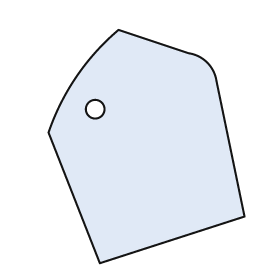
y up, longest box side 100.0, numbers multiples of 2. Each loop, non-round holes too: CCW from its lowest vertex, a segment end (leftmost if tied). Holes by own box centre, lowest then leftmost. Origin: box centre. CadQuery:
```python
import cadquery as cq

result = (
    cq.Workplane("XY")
    .moveTo(-20.0, -50.0)
    .lineTo(42.0, -30.0)
    .lineTo(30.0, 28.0)
    .threePointArc((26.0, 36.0), (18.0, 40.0))
    .lineTo(-12.0, 50.0)
    .threePointArc((-30.0, 30.0), (-42.0, 6.0))
    .close()
    .moveTo(-22.0, 16.0)
    .circle(4.0)
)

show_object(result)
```